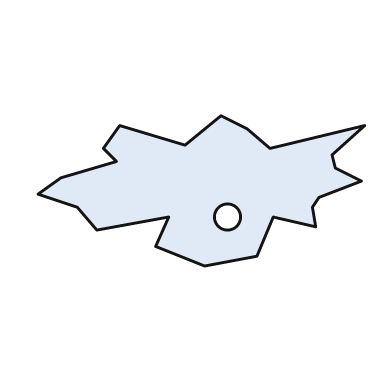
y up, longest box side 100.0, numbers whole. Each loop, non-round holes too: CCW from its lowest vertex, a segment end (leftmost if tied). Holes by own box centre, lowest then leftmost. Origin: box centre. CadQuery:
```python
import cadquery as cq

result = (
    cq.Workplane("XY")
    .moveTo(1.0, -23.0)
    .lineTo(17.0, -20.0)
    .lineTo(22.0, -8.0)
    .lineTo(35.0, -11.0)
    .lineTo(34.0, -5.0)
    .lineTo(36.0, -2.0)
    .lineTo(49.0, 3.0)
    .lineTo(41.0, 7.0)
    .lineTo(40.0, 11.0)
    .lineTo(50.0, 20.0)
    .lineTo(21.0, 13.0)
    .lineTo(14.0, 19.0)
    .lineTo(6.0, 23.0)
    .lineTo(-5.0, 14.0)
    .lineTo(-25.0, 20.0)
    .lineTo(-30.0, 13.0)
    .lineTo(-26.0, 9.0)
    .lineTo(-43.0, 4.0)
    .lineTo(-50.0, -1.0)
    .lineTo(-38.0, -5.0)
    .lineTo(-32.0, -12.0)
    .lineTo(-10.0, -8.0)
    .lineTo(-14.0, -17.0)
    .close()
    .moveTo(8.0, -8.0)
    .circle(4.0)
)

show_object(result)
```